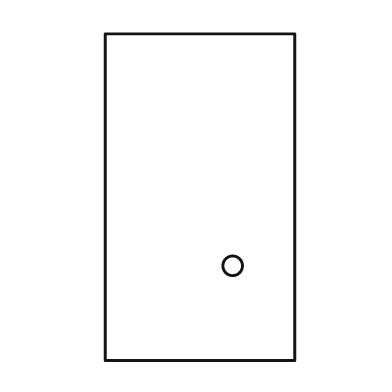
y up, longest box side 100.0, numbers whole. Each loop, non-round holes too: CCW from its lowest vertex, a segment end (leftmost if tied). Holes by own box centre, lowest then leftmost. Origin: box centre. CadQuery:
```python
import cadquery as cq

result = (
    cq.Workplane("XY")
    .moveTo(-29.0, -50.0)
    .lineTo(29.0, -50.0)
    .lineTo(29.0, 50.0)
    .lineTo(-29.0, 50.0)
    .close()
    .moveTo(10.0, -21.0)
    .circle(3.0)
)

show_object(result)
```